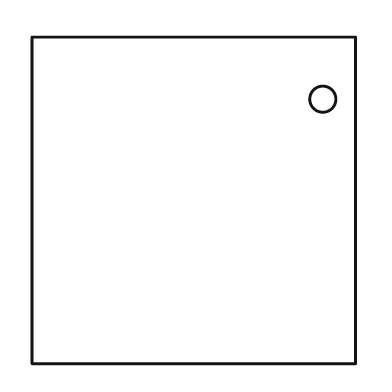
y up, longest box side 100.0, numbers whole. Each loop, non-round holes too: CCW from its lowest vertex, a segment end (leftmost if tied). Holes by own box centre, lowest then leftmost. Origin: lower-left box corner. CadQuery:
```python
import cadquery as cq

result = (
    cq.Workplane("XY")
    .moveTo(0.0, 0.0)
    .lineTo(99.0, 0.0)
    .lineTo(99.0, 100.0)
    .lineTo(0.0, 100.0)
    .close()
    .moveTo(89.0, 81.0)
    .circle(4.0)
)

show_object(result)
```